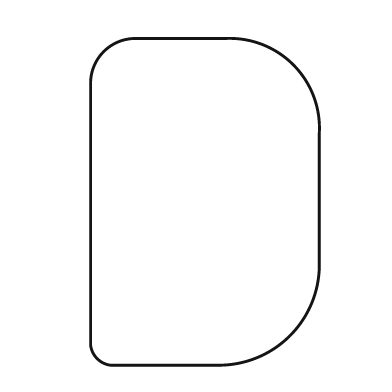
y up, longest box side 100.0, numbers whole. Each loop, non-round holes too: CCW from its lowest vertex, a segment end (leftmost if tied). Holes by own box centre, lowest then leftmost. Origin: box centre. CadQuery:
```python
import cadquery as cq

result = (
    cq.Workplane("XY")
    .moveTo(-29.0, -50.0)
    .lineTo(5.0, -50.0)
    .threePointArc((26.0, -41.0), (35.0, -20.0))
    .lineTo(35.0, 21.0)
    .threePointArc((27.0, 42.0), (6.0, 50.0))
    .lineTo(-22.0, 50.0)
    .threePointArc((-31.0, 46.0), (-35.0, 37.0))
    .lineTo(-35.0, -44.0)
    .threePointArc((-33.0, -48.0), (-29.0, -50.0))
    .close()
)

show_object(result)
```